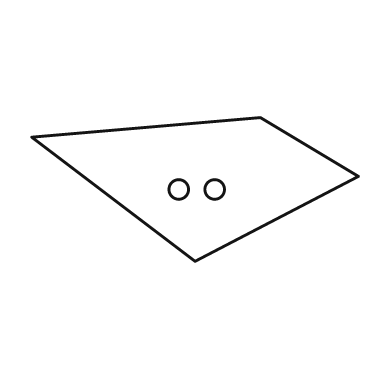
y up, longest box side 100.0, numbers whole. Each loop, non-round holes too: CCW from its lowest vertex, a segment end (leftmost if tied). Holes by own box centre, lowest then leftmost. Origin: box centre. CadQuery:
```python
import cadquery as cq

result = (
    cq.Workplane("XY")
    .moveTo(0.0, -22.0)
    .lineTo(50.0, 4.0)
    .lineTo(20.0, 22.0)
    .lineTo(-50.0, 16.0)
    .close()
    .moveTo(-5.0, 0.0)
    .circle(3.0)
    .moveTo(6.0, 0.0)
    .circle(3.0)
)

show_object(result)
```